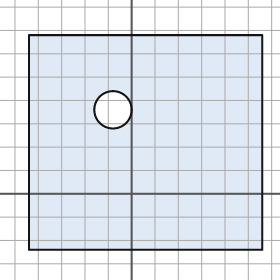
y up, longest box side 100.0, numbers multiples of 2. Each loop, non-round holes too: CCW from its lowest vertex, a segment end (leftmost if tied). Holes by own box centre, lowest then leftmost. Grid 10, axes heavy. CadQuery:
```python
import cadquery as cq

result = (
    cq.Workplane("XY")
    .moveTo(-44.0, -24.0)
    .lineTo(56.0, -24.0)
    .lineTo(56.0, 68.0)
    .lineTo(-44.0, 68.0)
    .close()
    .moveTo(-8.0, 36.0)
    .circle(8.0)
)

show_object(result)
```